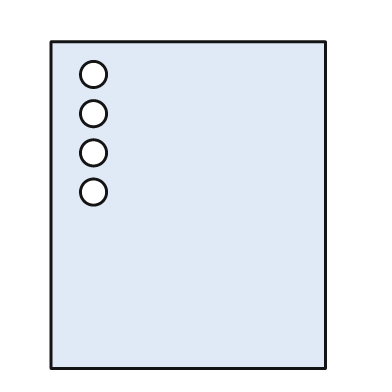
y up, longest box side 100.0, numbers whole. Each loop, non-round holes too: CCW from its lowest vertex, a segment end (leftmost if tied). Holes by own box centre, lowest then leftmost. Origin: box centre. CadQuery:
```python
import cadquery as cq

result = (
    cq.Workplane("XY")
    .moveTo(-42.0, -50.0)
    .lineTo(42.0, -50.0)
    .lineTo(42.0, 50.0)
    .lineTo(-42.0, 50.0)
    .close()
    .moveTo(-29.0, 4.0)
    .circle(4.0)
    .moveTo(-29.0, 16.0)
    .circle(4.0)
    .moveTo(-29.0, 28.0)
    .circle(4.0)
    .moveTo(-29.0, 40.0)
    .circle(4.0)
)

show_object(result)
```